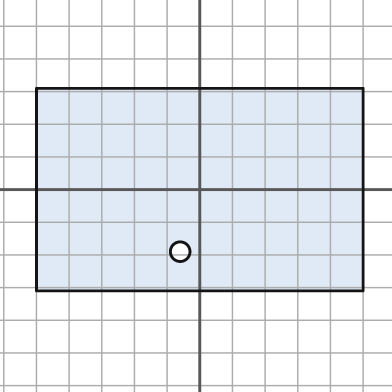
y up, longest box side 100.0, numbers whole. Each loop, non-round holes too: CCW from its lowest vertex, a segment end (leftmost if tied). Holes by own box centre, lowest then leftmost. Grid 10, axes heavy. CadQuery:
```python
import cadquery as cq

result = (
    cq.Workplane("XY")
    .moveTo(-50.0, -31.0)
    .lineTo(50.0, -31.0)
    .lineTo(50.0, 31.0)
    .lineTo(-50.0, 31.0)
    .close()
    .moveTo(-6.0, -19.0)
    .circle(3.0)
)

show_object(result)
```